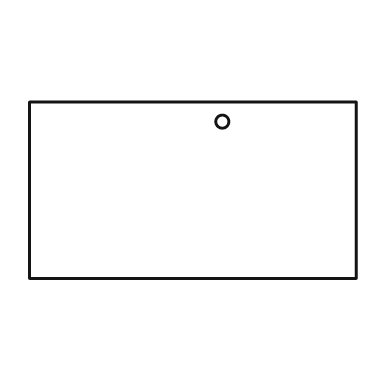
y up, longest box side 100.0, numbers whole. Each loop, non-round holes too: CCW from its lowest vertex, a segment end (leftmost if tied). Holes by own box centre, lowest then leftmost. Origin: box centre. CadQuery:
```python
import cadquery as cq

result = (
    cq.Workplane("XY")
    .moveTo(-50.0, -27.0)
    .lineTo(50.0, -27.0)
    .lineTo(50.0, 27.0)
    .lineTo(-50.0, 27.0)
    .close()
    .moveTo(9.0, 21.0)
    .circle(2.0)
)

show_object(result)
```